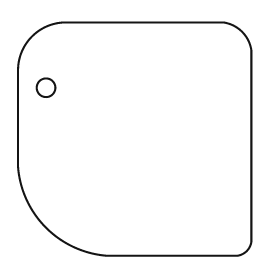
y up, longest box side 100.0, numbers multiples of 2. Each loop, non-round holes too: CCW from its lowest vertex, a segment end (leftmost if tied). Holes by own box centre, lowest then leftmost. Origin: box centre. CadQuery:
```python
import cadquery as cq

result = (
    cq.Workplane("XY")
    .moveTo(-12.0, -50.0)
    .lineTo(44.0, -50.0)
    .threePointArc((48.0, -48.0), (50.0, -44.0))
    .lineTo(50.0, 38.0)
    .threePointArc((46.0, 46.0), (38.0, 50.0))
    .lineTo(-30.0, 50.0)
    .threePointArc((-44.0, 44.0), (-50.0, 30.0))
    .lineTo(-50.0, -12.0)
    .threePointArc((-38.0, -38.0), (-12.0, -50.0))
    .close()
    .moveTo(-38.0, 22.0)
    .circle(4.0)
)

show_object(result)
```